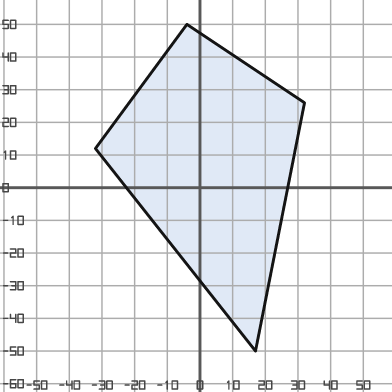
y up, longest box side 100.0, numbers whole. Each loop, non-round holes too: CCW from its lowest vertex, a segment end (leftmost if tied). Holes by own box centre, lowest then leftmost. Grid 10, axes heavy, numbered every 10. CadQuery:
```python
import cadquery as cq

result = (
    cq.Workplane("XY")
    .moveTo(17.0, -50.0)
    .lineTo(32.0, 26.0)
    .lineTo(-4.0, 50.0)
    .lineTo(-32.0, 12.0)
    .close()
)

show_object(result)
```